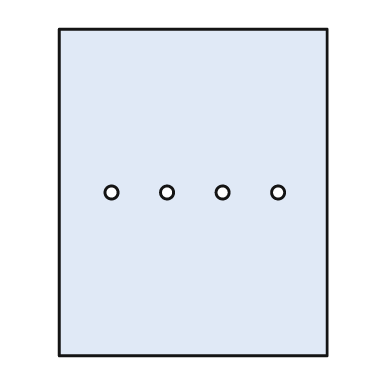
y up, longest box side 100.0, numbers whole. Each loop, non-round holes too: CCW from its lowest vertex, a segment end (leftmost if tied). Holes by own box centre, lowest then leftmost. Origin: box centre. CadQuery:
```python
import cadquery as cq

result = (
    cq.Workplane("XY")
    .moveTo(-41.0, -50.0)
    .lineTo(41.0, -50.0)
    .lineTo(41.0, 50.0)
    .lineTo(-41.0, 50.0)
    .close()
    .moveTo(-25.0, 0.0)
    .circle(2.0)
    .moveTo(-8.0, 0.0)
    .circle(2.0)
    .moveTo(9.0, 0.0)
    .circle(2.0)
    .moveTo(26.0, 0.0)
    .circle(2.0)
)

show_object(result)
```